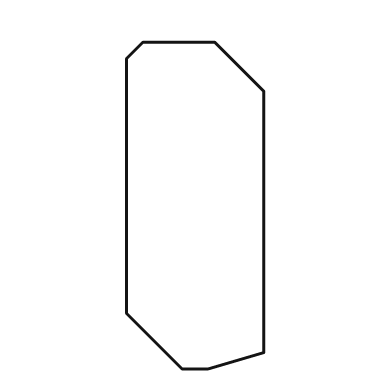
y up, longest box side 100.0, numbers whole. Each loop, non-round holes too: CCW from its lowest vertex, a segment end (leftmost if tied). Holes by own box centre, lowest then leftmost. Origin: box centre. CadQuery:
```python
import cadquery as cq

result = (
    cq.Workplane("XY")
    .moveTo(-4.0, -50.0)
    .lineTo(4.0, -50.0)
    .lineTo(21.0, -45.0)
    .lineTo(21.0, 35.0)
    .lineTo(6.0, 50.0)
    .lineTo(-16.0, 50.0)
    .lineTo(-21.0, 45.0)
    .lineTo(-21.0, -33.0)
    .close()
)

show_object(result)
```